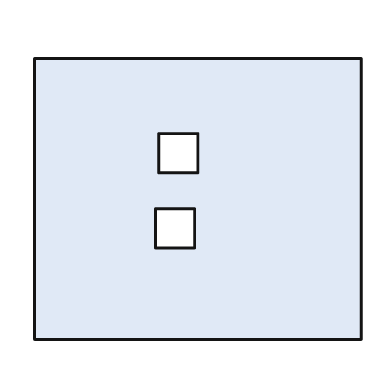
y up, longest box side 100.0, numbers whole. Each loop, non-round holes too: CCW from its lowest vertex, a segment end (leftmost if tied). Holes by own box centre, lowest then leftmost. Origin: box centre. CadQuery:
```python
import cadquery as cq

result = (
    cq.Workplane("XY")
    .moveTo(-50.0, -43.0)
    .lineTo(50.0, -43.0)
    .lineTo(50.0, 43.0)
    .lineTo(-50.0, 43.0)
    .close()
    .moveTo(-13.0, -15.0)
    .lineTo(-1.0, -15.0)
    .lineTo(-1.0, -3.0)
    .lineTo(-13.0, -3.0)
    .close()
    .moveTo(-12.0, 8.0)
    .lineTo(0.0, 8.0)
    .lineTo(0.0, 20.0)
    .lineTo(-12.0, 20.0)
    .close()
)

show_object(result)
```